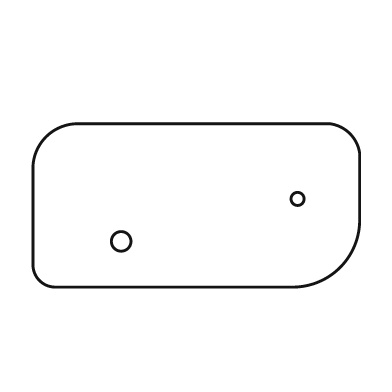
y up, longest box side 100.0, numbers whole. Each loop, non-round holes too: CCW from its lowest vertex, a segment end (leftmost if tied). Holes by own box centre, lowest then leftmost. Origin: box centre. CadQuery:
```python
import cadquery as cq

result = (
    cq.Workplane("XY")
    .moveTo(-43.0, -25.0)
    .lineTo(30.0, -25.0)
    .threePointArc((44.0, -19.0), (50.0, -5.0))
    .lineTo(50.0, 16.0)
    .threePointArc((47.0, 22.0), (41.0, 25.0))
    .lineTo(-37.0, 25.0)
    .threePointArc((-46.0, 21.0), (-50.0, 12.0))
    .lineTo(-50.0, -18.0)
    .threePointArc((-48.0, -23.0), (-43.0, -25.0))
    .close()
    .moveTo(-23.0, -11.0)
    .circle(3.0)
    .moveTo(31.0, 2.0)
    .circle(2.0)
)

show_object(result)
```